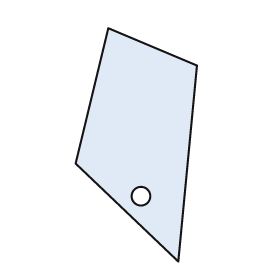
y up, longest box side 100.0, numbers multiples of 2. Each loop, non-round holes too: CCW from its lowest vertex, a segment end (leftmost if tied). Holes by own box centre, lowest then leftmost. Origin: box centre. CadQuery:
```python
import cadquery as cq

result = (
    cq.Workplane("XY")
    .moveTo(18.0, -50.0)
    .lineTo(26.0, 34.0)
    .lineTo(-12.0, 50.0)
    .lineTo(-26.0, -8.0)
    .close()
    .moveTo(2.0, -22.0)
    .circle(4.0)
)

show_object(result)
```